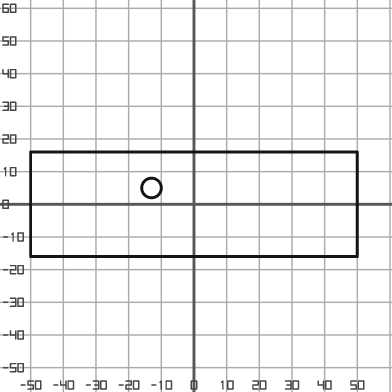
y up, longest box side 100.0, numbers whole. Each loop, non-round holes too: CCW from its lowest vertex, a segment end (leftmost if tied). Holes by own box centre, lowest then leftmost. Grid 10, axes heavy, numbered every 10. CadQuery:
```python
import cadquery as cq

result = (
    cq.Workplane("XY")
    .moveTo(-50.0, -16.0)
    .lineTo(50.0, -16.0)
    .lineTo(50.0, 16.0)
    .lineTo(-50.0, 16.0)
    .close()
    .moveTo(-13.0, 5.0)
    .circle(3.0)
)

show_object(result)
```